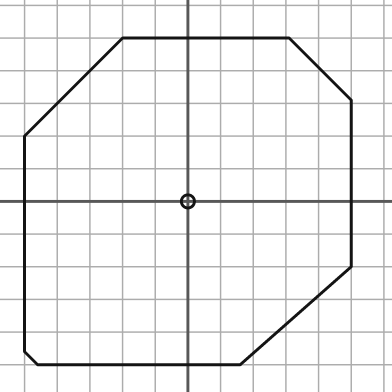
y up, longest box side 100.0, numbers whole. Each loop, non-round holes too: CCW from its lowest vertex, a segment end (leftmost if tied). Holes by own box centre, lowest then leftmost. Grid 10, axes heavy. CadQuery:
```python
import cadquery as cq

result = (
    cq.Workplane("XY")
    .moveTo(-46.0, -50.0)
    .lineTo(16.0, -50.0)
    .lineTo(50.0, -20.0)
    .lineTo(50.0, 31.0)
    .lineTo(31.0, 50.0)
    .lineTo(-20.0, 50.0)
    .lineTo(-50.0, 20.0)
    .lineTo(-50.0, -46.0)
    .close()
    .moveTo(0.0, 0.0)
    .circle(2.0)
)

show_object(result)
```